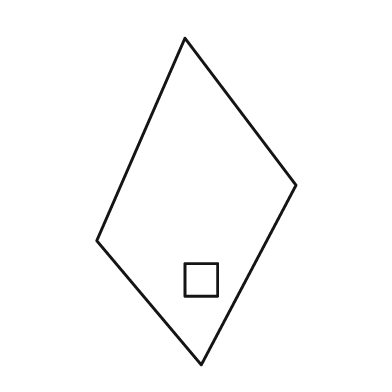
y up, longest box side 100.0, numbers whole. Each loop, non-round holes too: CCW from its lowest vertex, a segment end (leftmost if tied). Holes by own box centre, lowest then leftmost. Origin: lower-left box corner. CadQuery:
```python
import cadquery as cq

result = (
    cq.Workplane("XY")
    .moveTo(32.0, 0.0)
    .lineTo(61.0, 55.0)
    .lineTo(27.0, 100.0)
    .lineTo(0.0, 38.0)
    .close()
    .moveTo(27.0, 21.0)
    .lineTo(37.0, 21.0)
    .lineTo(37.0, 31.0)
    .lineTo(27.0, 31.0)
    .close()
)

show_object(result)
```